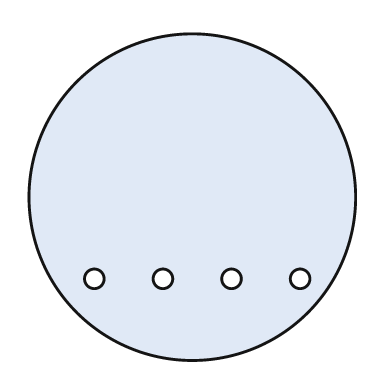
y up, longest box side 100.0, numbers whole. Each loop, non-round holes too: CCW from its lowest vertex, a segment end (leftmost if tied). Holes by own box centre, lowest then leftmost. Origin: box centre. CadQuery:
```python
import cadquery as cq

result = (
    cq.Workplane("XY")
    .moveTo(0.0, 0.0)
    .circle(50.0)
    .moveTo(-30.0, -25.0)
    .circle(3.0)
    .moveTo(-9.0, -25.0)
    .circle(3.0)
    .moveTo(12.0, -25.0)
    .circle(3.0)
    .moveTo(33.0, -25.0)
    .circle(3.0)
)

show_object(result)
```